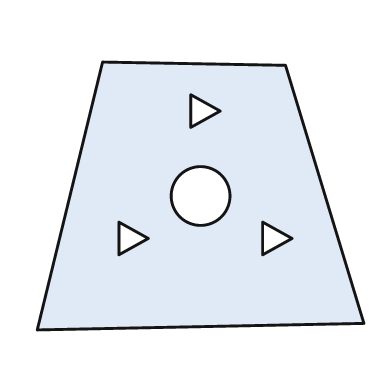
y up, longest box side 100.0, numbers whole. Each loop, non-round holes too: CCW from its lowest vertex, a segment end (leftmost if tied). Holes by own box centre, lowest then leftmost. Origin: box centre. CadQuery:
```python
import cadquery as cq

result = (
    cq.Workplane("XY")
    .moveTo(-50.0, -41.0)
    .lineTo(50.0, -39.0)
    .lineTo(26.0, 40.0)
    .lineTo(-30.0, 41.0)
    .close()
    .moveTo(-25.0, -18.0)
    .lineTo(-16.0, -13.0)
    .lineTo(-25.0, -8.0)
    .close()
    .moveTo(19.0, -18.0)
    .lineTo(28.0, -13.0)
    .lineTo(19.0, -8.0)
    .close()
    .moveTo(0.0, 0.0)
    .circle(9.0)
    .moveTo(-3.0, 21.0)
    .lineTo(6.0, 26.0)
    .lineTo(-3.0, 31.0)
    .close()
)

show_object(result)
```